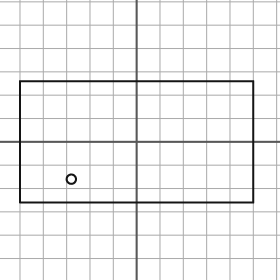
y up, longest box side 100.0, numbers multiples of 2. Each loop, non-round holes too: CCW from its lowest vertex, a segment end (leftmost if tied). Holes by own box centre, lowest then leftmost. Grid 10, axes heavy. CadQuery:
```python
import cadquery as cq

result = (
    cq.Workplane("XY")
    .moveTo(-50.0, -26.0)
    .lineTo(50.0, -26.0)
    .lineTo(50.0, 26.0)
    .lineTo(-50.0, 26.0)
    .close()
    .moveTo(-28.0, -16.0)
    .circle(2.0)
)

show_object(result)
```